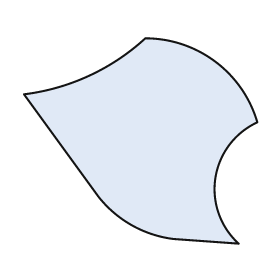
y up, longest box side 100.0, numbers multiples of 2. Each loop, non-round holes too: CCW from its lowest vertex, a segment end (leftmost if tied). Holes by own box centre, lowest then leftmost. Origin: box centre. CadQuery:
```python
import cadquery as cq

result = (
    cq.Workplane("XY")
    .moveTo(42.0, -44.0)
    .threePointArc((32.0, -16.0), (50.0, 8.0))
    .threePointArc((32.0, 34.0), (2.0, 44.0))
    .threePointArc((-22.0, 28.0), (-50.0, 20.0))
    .lineTo(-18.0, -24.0)
    .threePointArc((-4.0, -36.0), (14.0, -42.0))
    .close()
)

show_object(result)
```